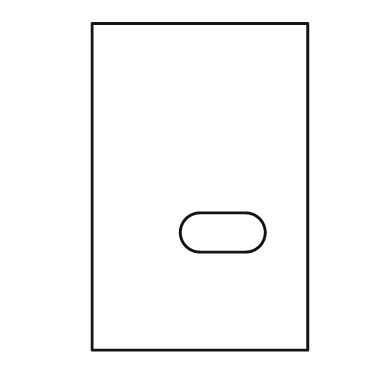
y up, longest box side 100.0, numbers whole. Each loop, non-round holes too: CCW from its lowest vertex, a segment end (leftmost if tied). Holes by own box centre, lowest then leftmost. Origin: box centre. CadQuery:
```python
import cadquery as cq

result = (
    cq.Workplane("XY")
    .moveTo(-33.0, -50.0)
    .lineTo(33.0, -50.0)
    .lineTo(33.0, 50.0)
    .lineTo(-33.0, 50.0)
    .close()
    .moveTo(0.0, -20.0)
    .lineTo(14.0, -20.0)
    .threePointArc((20.0, -14.0), (14.0, -8.0))
    .lineTo(0.0, -8.0)
    .threePointArc((-6.0, -14.0), (0.0, -20.0))
    .close()
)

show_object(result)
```